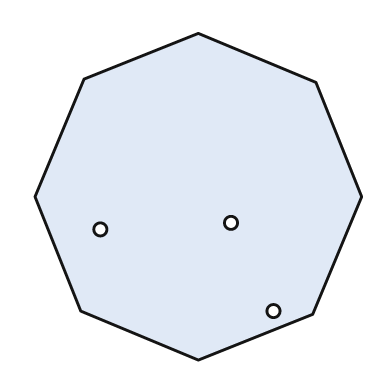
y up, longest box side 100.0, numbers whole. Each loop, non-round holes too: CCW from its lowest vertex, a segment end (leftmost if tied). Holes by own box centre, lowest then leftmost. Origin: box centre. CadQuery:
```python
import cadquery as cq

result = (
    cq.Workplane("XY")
    .moveTo(0.0, -50.0)
    .lineTo(35.0, -36.0)
    .lineTo(50.0, 0.0)
    .lineTo(36.0, 35.0)
    .lineTo(0.0, 50.0)
    .lineTo(-35.0, 36.0)
    .lineTo(-50.0, 0.0)
    .lineTo(-36.0, -35.0)
    .close()
    .moveTo(23.0, -35.0)
    .circle(2.0)
    .moveTo(-30.0, -10.0)
    .circle(2.0)
    .moveTo(10.0, -8.0)
    .circle(2.0)
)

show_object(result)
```